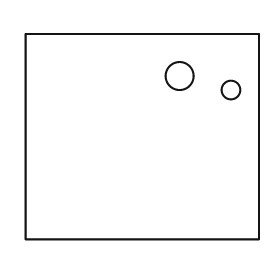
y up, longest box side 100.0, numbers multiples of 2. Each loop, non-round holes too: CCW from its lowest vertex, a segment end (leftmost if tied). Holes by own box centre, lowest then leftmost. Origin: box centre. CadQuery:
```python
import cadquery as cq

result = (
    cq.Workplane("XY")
    .moveTo(-50.0, -44.0)
    .lineTo(50.0, -44.0)
    .lineTo(50.0, 44.0)
    .lineTo(-50.0, 44.0)
    .close()
    .moveTo(38.0, 20.0)
    .circle(4.0)
    .moveTo(16.0, 26.0)
    .circle(6.0)
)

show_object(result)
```